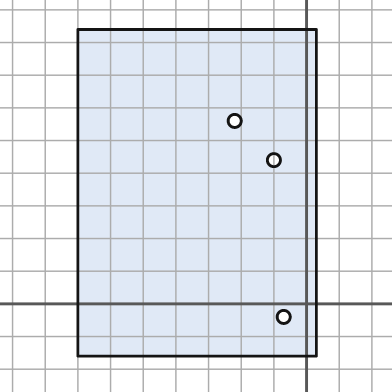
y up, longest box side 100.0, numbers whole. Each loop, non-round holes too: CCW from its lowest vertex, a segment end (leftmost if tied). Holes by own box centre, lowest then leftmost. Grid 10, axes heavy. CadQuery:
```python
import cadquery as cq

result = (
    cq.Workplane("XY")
    .moveTo(-70.0, -16.0)
    .lineTo(3.0, -16.0)
    .lineTo(3.0, 84.0)
    .lineTo(-70.0, 84.0)
    .close()
    .moveTo(-7.0, -4.0)
    .circle(2.0)
    .moveTo(-10.0, 44.0)
    .circle(2.0)
    .moveTo(-22.0, 56.0)
    .circle(2.0)
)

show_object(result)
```